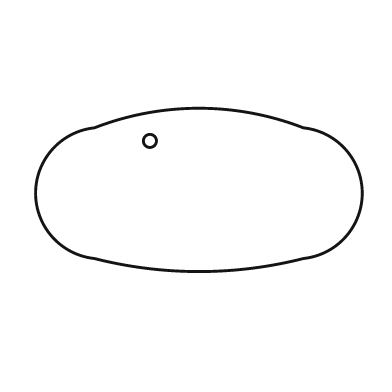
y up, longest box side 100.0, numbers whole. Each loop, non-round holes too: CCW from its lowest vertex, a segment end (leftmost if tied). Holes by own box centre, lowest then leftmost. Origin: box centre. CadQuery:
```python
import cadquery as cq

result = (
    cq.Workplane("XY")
    .moveTo(-32.0, -21.0)
    .threePointArc((0.0, -25.0), (32.0, -21.0))
    .threePointArc((50.0, -1.0), (32.0, 19.0))
    .threePointArc((0.0, 25.0), (-32.0, 19.0))
    .threePointArc((-50.0, -1.0), (-32.0, -21.0))
    .close()
    .moveTo(-15.0, 15.0)
    .circle(2.0)
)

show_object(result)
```